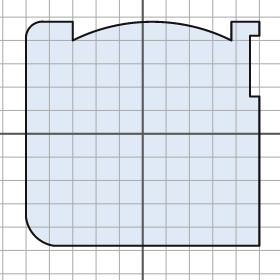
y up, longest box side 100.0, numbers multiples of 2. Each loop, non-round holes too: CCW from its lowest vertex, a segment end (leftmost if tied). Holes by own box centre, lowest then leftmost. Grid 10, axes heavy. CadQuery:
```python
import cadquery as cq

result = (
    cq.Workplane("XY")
    .moveTo(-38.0, -48.0)
    .lineTo(50.0, -48.0)
    .lineTo(50.0, 16.0)
    .lineTo(46.0, 16.0)
    .lineTo(46.0, 42.0)
    .lineTo(50.0, 42.0)
    .lineTo(50.0, 48.0)
    .lineTo(38.0, 48.0)
    .lineTo(38.0, 40.0)
    .threePointArc((4.0, 48.0), (-30.0, 40.0))
    .lineTo(-30.0, 48.0)
    .lineTo(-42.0, 48.0)
    .threePointArc((-48.0, 46.0), (-50.0, 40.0))
    .lineTo(-50.0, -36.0)
    .threePointArc((-46.0, -44.0), (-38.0, -48.0))
    .close()
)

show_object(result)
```